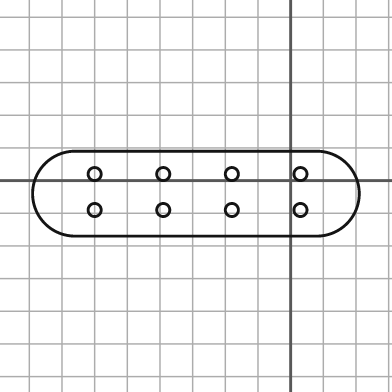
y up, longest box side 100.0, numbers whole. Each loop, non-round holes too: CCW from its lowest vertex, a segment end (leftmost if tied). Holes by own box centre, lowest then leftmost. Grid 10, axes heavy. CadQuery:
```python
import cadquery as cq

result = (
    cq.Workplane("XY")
    .moveTo(-66.0, -17.0)
    .lineTo(8.0, -17.0)
    .threePointArc((21.0, -4.0), (8.0, 9.0))
    .lineTo(-66.0, 9.0)
    .threePointArc((-79.0, -4.0), (-66.0, -17.0))
    .close()
    .moveTo(-60.0, -9.0)
    .circle(2.0)
    .moveTo(-39.0, -9.0)
    .circle(2.0)
    .moveTo(-18.0, -9.0)
    .circle(2.0)
    .moveTo(3.0, -9.0)
    .circle(2.0)
    .moveTo(-60.0, 2.0)
    .circle(2.0)
    .moveTo(-39.0, 2.0)
    .circle(2.0)
    .moveTo(-18.0, 2.0)
    .circle(2.0)
    .moveTo(3.0, 2.0)
    .circle(2.0)
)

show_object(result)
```